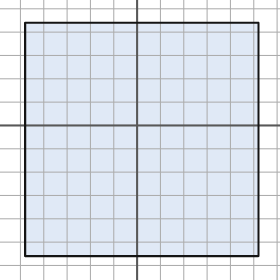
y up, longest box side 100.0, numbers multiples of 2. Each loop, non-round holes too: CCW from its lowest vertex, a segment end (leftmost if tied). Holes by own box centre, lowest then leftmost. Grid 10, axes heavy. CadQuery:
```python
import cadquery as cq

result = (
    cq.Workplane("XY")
    .moveTo(-48.0, -56.0)
    .lineTo(52.0, -56.0)
    .lineTo(52.0, 44.0)
    .lineTo(-48.0, 44.0)
    .close()
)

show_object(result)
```